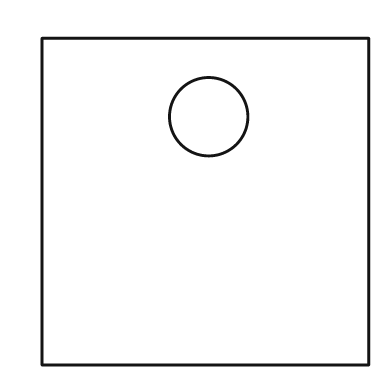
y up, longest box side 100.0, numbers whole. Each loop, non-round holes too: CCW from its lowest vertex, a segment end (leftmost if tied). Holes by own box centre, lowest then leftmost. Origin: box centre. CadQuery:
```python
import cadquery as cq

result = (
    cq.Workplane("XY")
    .moveTo(-50.0, -50.0)
    .lineTo(50.0, -50.0)
    .lineTo(50.0, 50.0)
    .lineTo(-50.0, 50.0)
    .close()
    .moveTo(1.0, 26.0)
    .circle(12.0)
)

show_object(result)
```